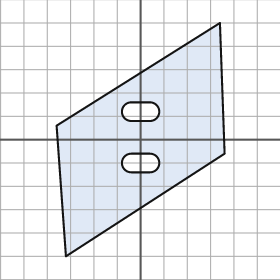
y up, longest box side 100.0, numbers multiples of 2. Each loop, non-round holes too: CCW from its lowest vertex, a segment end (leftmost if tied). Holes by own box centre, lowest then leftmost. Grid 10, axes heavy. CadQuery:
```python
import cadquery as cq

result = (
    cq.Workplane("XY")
    .moveTo(-32.0, -50.0)
    .lineTo(36.0, -6.0)
    .lineTo(34.0, 50.0)
    .lineTo(-36.0, 6.0)
    .close()
    .moveTo(-4.0, -14.0)
    .lineTo(4.0, -14.0)
    .threePointArc((8.0, -10.0), (4.0, -6.0))
    .lineTo(-4.0, -6.0)
    .threePointArc((-8.0, -10.0), (-4.0, -14.0))
    .close()
    .moveTo(-4.0, 8.0)
    .lineTo(4.0, 8.0)
    .threePointArc((8.0, 12.0), (4.0, 16.0))
    .lineTo(-4.0, 16.0)
    .threePointArc((-8.0, 12.0), (-4.0, 8.0))
    .close()
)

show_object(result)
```